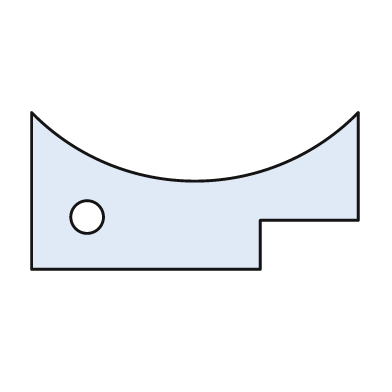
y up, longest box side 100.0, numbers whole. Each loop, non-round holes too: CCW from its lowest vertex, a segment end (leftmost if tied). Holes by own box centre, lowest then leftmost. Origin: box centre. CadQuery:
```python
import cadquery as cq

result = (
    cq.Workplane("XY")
    .moveTo(-50.0, -24.0)
    .lineTo(20.0, -24.0)
    .lineTo(20.0, -9.0)
    .lineTo(50.0, -9.0)
    .lineTo(50.0, 24.0)
    .threePointArc((0.0, 3.0), (-50.0, 24.0))
    .close()
    .moveTo(-33.0, -8.0)
    .circle(5.0)
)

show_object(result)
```